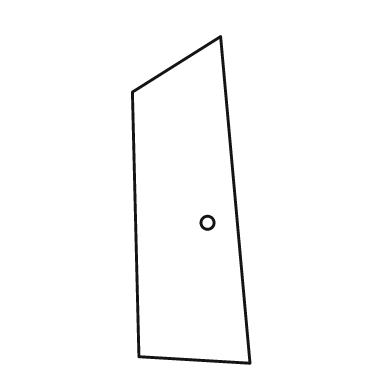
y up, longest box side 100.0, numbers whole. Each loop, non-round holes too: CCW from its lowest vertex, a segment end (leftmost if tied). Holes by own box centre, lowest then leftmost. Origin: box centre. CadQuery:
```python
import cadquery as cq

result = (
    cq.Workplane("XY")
    .moveTo(18.0, -50.0)
    .lineTo(9.0, 50.0)
    .lineTo(-18.0, 33.0)
    .lineTo(-16.0, -48.0)
    .close()
    .moveTo(5.0, -7.0)
    .circle(2.0)
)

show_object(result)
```